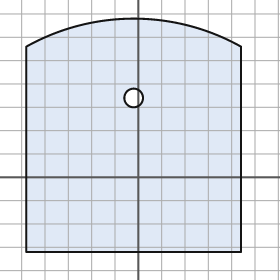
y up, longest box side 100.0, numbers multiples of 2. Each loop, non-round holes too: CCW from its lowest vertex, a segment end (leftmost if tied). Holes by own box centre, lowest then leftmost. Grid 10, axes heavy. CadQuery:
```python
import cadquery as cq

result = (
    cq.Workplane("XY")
    .moveTo(-48.0, -32.0)
    .lineTo(44.0, -32.0)
    .lineTo(44.0, 56.0)
    .threePointArc((-2.0, 68.0), (-48.0, 56.0))
    .close()
    .moveTo(-2.0, 34.0)
    .circle(4.0)
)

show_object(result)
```